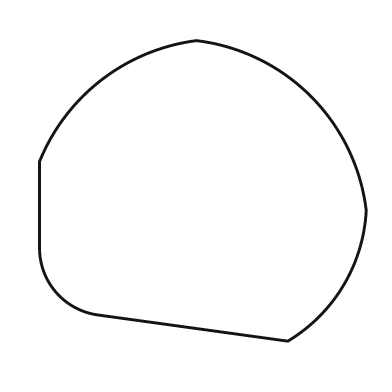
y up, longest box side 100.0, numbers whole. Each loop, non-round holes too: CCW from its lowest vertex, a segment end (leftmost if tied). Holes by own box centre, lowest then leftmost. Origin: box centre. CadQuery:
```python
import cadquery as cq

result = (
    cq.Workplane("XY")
    .moveTo(26.0, -46.0)
    .threePointArc((43.0, -29.0), (50.0, -6.0))
    .threePointArc((33.0, 29.0), (-2.0, 46.0))
    .threePointArc((-31.0, 34.0), (-50.0, 9.0))
    .lineTo(-50.0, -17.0)
    .threePointArc((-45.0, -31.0), (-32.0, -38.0))
    .close()
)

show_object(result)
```